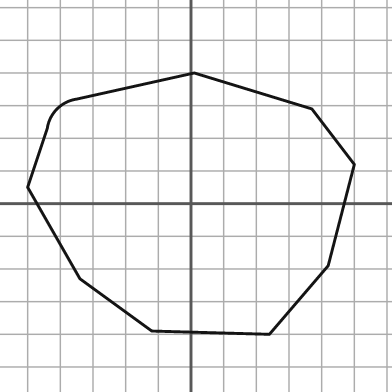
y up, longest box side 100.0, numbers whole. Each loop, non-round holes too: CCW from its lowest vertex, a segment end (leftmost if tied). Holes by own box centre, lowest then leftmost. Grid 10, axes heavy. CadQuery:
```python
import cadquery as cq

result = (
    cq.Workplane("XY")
    .moveTo(24.0, -40.0)
    .lineTo(42.0, -19.0)
    .lineTo(50.0, 12.0)
    .lineTo(37.0, 29.0)
    .lineTo(1.0, 40.0)
    .lineTo(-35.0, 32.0)
    .threePointArc((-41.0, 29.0), (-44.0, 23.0))
    .lineTo(-50.0, 5.0)
    .lineTo(-34.0, -23.0)
    .lineTo(-12.0, -39.0)
    .close()
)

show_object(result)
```